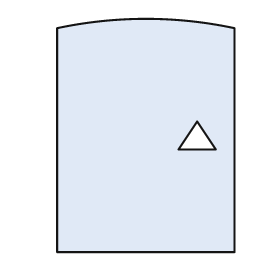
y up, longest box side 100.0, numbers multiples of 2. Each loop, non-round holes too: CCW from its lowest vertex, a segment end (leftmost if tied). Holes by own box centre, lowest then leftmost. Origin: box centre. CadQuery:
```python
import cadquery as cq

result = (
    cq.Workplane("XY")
    .moveTo(-38.0, -50.0)
    .lineTo(38.0, -50.0)
    .lineTo(38.0, 46.0)
    .threePointArc((0.0, 50.0), (-38.0, 46.0))
    .close()
    .moveTo(14.0, -6.0)
    .lineTo(30.0, -6.0)
    .lineTo(22.0, 6.0)
    .close()
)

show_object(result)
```